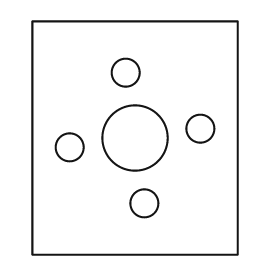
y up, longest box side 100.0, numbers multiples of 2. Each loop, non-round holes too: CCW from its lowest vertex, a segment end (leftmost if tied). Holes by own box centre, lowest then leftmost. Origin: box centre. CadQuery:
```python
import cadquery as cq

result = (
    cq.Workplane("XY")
    .moveTo(-44.0, -50.0)
    .lineTo(44.0, -50.0)
    .lineTo(44.0, 50.0)
    .lineTo(-44.0, 50.0)
    .close()
    .moveTo(4.0, -28.0)
    .circle(6.0)
    .moveTo(-28.0, -4.0)
    .circle(6.0)
    .moveTo(0.0, 0.0)
    .circle(14.0)
    .moveTo(28.0, 4.0)
    .circle(6.0)
    .moveTo(-4.0, 28.0)
    .circle(6.0)
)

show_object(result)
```